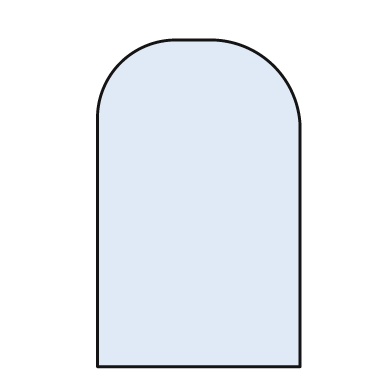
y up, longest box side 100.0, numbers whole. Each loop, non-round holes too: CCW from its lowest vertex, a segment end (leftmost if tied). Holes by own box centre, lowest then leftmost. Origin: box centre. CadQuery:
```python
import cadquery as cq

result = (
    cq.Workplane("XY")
    .moveTo(-31.0, -50.0)
    .lineTo(31.0, -50.0)
    .lineTo(31.0, 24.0)
    .threePointArc((23.0, 42.0), (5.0, 50.0))
    .lineTo(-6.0, 50.0)
    .threePointArc((-24.0, 43.0), (-31.0, 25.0))
    .close()
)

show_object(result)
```